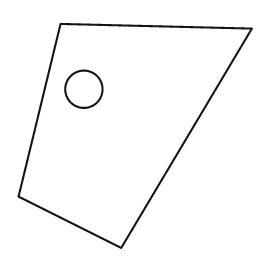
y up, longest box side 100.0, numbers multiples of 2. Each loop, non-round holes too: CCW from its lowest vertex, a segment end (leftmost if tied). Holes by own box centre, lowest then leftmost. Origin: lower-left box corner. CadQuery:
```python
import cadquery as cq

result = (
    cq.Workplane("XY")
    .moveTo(44.0, 0.0)
    .lineTo(100.0, 94.0)
    .lineTo(18.0, 96.0)
    .lineTo(0.0, 22.0)
    .close()
    .moveTo(28.0, 68.0)
    .circle(8.0)
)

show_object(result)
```